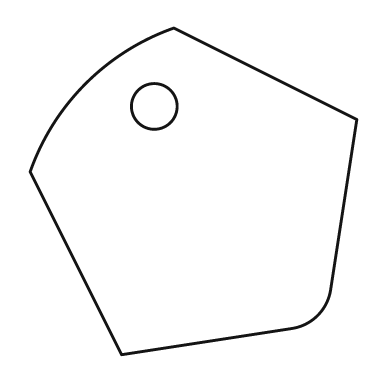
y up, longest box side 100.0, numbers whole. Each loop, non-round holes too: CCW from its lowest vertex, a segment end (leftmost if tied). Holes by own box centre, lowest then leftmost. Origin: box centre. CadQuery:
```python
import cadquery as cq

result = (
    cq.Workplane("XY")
    .moveTo(-22.0, -50.0)
    .lineTo(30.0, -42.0)
    .threePointArc((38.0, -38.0), (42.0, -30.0))
    .lineTo(50.0, 22.0)
    .lineTo(-6.0, 50.0)
    .threePointArc((-33.0, 33.0), (-50.0, 6.0))
    .close()
    .moveTo(-12.0, 26.0)
    .circle(7.0)
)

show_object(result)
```